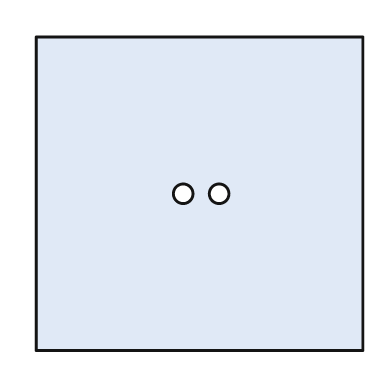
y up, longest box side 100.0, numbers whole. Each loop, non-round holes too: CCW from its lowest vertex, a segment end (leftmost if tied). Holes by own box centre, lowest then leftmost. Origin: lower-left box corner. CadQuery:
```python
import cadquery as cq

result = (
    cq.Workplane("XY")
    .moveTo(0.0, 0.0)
    .lineTo(100.0, 0.0)
    .lineTo(100.0, 96.0)
    .lineTo(0.0, 96.0)
    .close()
    .moveTo(45.0, 48.0)
    .circle(3.0)
    .moveTo(56.0, 48.0)
    .circle(3.0)
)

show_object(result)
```